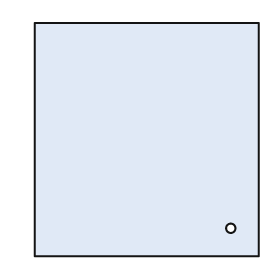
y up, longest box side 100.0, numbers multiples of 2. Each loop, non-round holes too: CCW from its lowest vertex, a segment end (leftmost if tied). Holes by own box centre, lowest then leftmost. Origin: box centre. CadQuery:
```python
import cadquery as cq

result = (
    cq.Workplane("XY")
    .moveTo(-48.0, -50.0)
    .lineTo(48.0, -50.0)
    .lineTo(48.0, 50.0)
    .lineTo(-48.0, 50.0)
    .close()
    .moveTo(36.0, -38.0)
    .circle(2.0)
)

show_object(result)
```